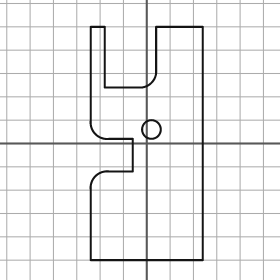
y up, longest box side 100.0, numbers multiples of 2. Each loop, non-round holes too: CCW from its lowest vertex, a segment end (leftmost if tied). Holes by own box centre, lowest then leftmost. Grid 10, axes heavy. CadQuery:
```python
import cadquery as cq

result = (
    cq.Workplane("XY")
    .moveTo(-24.0, -50.0)
    .lineTo(24.0, -50.0)
    .lineTo(24.0, 50.0)
    .lineTo(4.0, 50.0)
    .lineTo(4.0, 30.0)
    .threePointArc((2.0, 26.0), (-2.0, 24.0))
    .lineTo(-18.0, 24.0)
    .lineTo(-18.0, 50.0)
    .lineTo(-24.0, 50.0)
    .lineTo(-24.0, 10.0)
    .threePointArc((-22.0, 4.0), (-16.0, 2.0))
    .lineTo(-6.0, 2.0)
    .lineTo(-6.0, -12.0)
    .lineTo(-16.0, -12.0)
    .threePointArc((-22.0, -14.0), (-24.0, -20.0))
    .close()
    .moveTo(2.0, 6.0)
    .circle(4.0)
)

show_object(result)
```